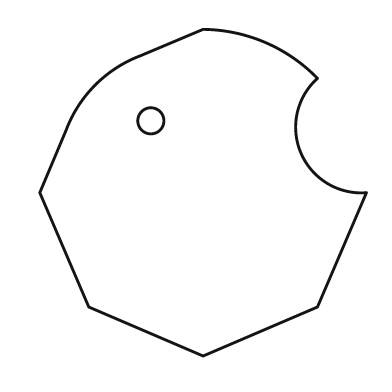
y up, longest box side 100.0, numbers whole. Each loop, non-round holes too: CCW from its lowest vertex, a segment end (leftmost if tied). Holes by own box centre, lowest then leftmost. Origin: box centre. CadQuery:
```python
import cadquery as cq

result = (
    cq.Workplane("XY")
    .moveTo(0.0, -50.0)
    .lineTo(35.0, -35.0)
    .lineTo(50.0, 0.0)
    .threePointArc((30.0, 12.0), (35.0, 35.0))
    .threePointArc((19.0, 46.0), (0.0, 50.0))
    .lineTo(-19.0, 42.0)
    .threePointArc((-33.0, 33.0), (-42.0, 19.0))
    .lineTo(-50.0, 0.0)
    .lineTo(-35.0, -35.0)
    .close()
    .moveTo(-16.0, 22.0)
    .circle(4.0)
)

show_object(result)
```